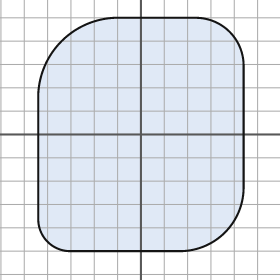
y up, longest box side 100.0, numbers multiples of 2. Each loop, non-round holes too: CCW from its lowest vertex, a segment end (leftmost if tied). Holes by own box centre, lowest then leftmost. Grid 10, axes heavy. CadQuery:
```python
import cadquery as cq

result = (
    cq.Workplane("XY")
    .moveTo(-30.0, -50.0)
    .lineTo(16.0, -50.0)
    .threePointArc((36.0, -42.0), (44.0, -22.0))
    .lineTo(44.0, 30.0)
    .threePointArc((38.0, 44.0), (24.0, 50.0))
    .lineTo(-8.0, 50.0)
    .threePointArc((-34.0, 40.0), (-44.0, 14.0))
    .lineTo(-44.0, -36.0)
    .threePointArc((-40.0, -46.0), (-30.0, -50.0))
    .close()
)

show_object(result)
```